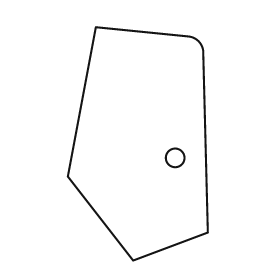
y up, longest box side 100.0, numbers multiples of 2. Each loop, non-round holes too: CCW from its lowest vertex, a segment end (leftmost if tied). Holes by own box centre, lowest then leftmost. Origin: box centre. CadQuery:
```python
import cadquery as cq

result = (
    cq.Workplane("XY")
    .moveTo(-2.0, -50.0)
    .lineTo(30.0, -38.0)
    .lineTo(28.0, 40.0)
    .threePointArc((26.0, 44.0), (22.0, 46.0))
    .lineTo(-18.0, 50.0)
    .lineTo(-30.0, -14.0)
    .close()
    .moveTo(16.0, -6.0)
    .circle(4.0)
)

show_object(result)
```